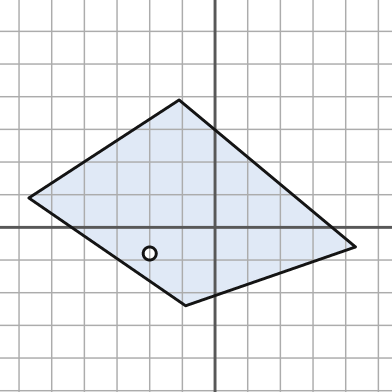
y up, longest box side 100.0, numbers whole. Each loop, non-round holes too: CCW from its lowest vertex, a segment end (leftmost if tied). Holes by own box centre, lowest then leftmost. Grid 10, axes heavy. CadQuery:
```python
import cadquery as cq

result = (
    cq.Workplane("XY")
    .moveTo(-9.0, -24.0)
    .lineTo(43.0, -6.0)
    .lineTo(-11.0, 39.0)
    .lineTo(-57.0, 9.0)
    .close()
    .moveTo(-20.0, -8.0)
    .circle(2.0)
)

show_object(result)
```